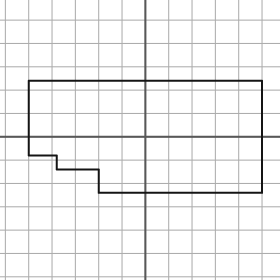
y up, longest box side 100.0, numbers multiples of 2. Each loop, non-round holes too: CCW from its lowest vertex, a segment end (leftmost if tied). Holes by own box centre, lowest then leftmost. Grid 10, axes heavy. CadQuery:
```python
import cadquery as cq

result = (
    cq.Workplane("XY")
    .moveTo(-20.0, -24.0)
    .lineTo(50.0, -24.0)
    .lineTo(50.0, 24.0)
    .lineTo(-50.0, 24.0)
    .lineTo(-50.0, -8.0)
    .lineTo(-38.0, -8.0)
    .lineTo(-38.0, -14.0)
    .lineTo(-20.0, -14.0)
    .close()
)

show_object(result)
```